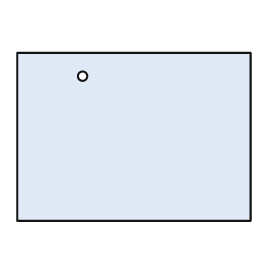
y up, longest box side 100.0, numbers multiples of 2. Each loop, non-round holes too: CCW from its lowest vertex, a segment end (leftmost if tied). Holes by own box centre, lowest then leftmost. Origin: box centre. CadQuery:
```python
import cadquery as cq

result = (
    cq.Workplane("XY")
    .moveTo(-50.0, -36.0)
    .lineTo(50.0, -36.0)
    .lineTo(50.0, 36.0)
    .lineTo(-50.0, 36.0)
    .close()
    .moveTo(-22.0, 26.0)
    .circle(2.0)
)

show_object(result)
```